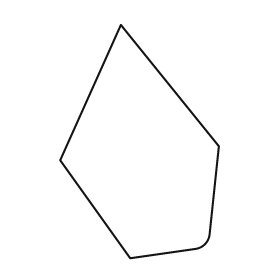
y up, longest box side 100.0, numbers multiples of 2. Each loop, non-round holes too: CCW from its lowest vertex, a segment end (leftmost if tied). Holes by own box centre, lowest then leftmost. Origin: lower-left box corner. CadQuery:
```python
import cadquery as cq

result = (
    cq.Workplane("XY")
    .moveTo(30.0, 0.0)
    .lineTo(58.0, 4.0)
    .threePointArc((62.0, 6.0), (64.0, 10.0))
    .lineTo(68.0, 48.0)
    .lineTo(26.0, 100.0)
    .lineTo(0.0, 42.0)
    .close()
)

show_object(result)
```